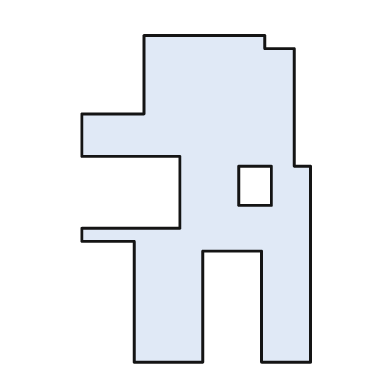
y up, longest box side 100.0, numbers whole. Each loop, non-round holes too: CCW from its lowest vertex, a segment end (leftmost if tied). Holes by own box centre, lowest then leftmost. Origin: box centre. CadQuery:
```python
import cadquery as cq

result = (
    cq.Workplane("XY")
    .moveTo(-19.0, -50.0)
    .lineTo(2.0, -50.0)
    .lineTo(2.0, -16.0)
    .lineTo(20.0, -16.0)
    .lineTo(20.0, -50.0)
    .lineTo(35.0, -50.0)
    .lineTo(35.0, 10.0)
    .lineTo(30.0, 10.0)
    .lineTo(30.0, 46.0)
    .lineTo(21.0, 46.0)
    .lineTo(21.0, 50.0)
    .lineTo(-16.0, 50.0)
    .lineTo(-16.0, 26.0)
    .lineTo(-35.0, 26.0)
    .lineTo(-35.0, 13.0)
    .lineTo(-5.0, 13.0)
    .lineTo(-5.0, -9.0)
    .lineTo(-35.0, -9.0)
    .lineTo(-35.0, -13.0)
    .lineTo(-19.0, -13.0)
    .close()
    .moveTo(13.0, -2.0)
    .lineTo(23.0, -2.0)
    .lineTo(23.0, 10.0)
    .lineTo(13.0, 10.0)
    .close()
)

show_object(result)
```